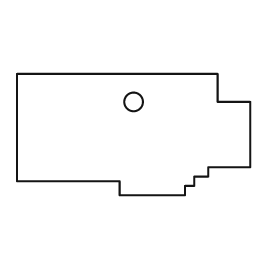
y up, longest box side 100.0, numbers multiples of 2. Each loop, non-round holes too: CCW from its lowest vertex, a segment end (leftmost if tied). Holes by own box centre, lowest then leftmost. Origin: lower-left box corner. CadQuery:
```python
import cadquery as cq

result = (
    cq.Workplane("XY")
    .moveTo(44.0, 0.0)
    .lineTo(72.0, 0.0)
    .lineTo(72.0, 4.0)
    .lineTo(76.0, 4.0)
    .lineTo(76.0, 8.0)
    .lineTo(82.0, 8.0)
    .lineTo(82.0, 12.0)
    .lineTo(100.0, 12.0)
    .lineTo(100.0, 40.0)
    .lineTo(86.0, 40.0)
    .lineTo(86.0, 52.0)
    .lineTo(0.0, 52.0)
    .lineTo(0.0, 6.0)
    .lineTo(44.0, 6.0)
    .close()
    .moveTo(50.0, 40.0)
    .circle(4.0)
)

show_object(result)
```